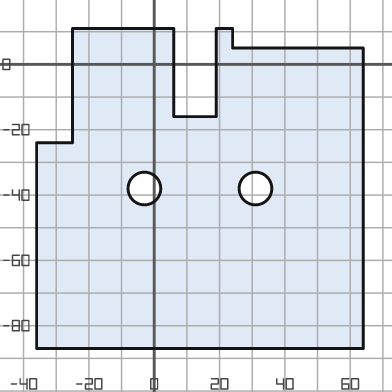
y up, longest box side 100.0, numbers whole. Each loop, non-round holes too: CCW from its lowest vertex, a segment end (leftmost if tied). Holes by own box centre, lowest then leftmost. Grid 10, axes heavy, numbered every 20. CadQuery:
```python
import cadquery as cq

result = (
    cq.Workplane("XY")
    .moveTo(-36.0, -87.0)
    .lineTo(64.0, -87.0)
    .lineTo(64.0, 5.0)
    .lineTo(24.0, 5.0)
    .lineTo(24.0, 11.0)
    .lineTo(19.0, 11.0)
    .lineTo(19.0, -16.0)
    .lineTo(6.0, -16.0)
    .lineTo(6.0, 11.0)
    .lineTo(-25.0, 11.0)
    .lineTo(-25.0, -24.0)
    .lineTo(-36.0, -24.0)
    .close()
    .moveTo(-3.0, -38.0)
    .circle(5.0)
    .moveTo(31.0, -38.0)
    .circle(5.0)
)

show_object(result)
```